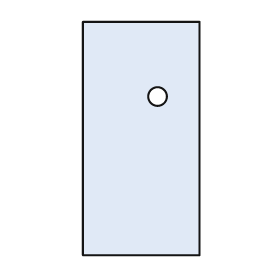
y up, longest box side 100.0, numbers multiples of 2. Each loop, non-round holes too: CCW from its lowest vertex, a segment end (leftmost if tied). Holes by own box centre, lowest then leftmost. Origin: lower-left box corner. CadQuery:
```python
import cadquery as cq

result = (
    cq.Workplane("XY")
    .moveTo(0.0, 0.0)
    .lineTo(50.0, 0.0)
    .lineTo(50.0, 100.0)
    .lineTo(0.0, 100.0)
    .close()
    .moveTo(32.0, 68.0)
    .circle(4.0)
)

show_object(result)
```